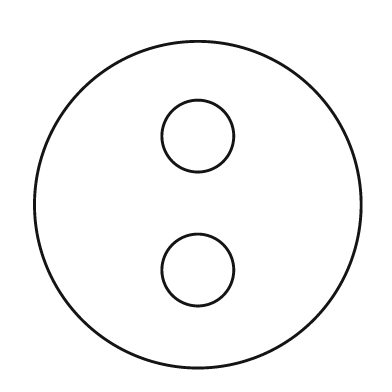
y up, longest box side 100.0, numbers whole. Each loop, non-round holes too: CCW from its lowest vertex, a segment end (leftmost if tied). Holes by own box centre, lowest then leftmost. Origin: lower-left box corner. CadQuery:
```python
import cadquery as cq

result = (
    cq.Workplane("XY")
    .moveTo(50.0, 50.0)
    .circle(50.0)
    .moveTo(50.0, 30.0)
    .circle(11.0)
    .moveTo(50.0, 71.0)
    .circle(11.0)
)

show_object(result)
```